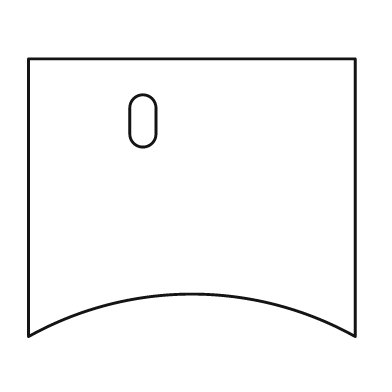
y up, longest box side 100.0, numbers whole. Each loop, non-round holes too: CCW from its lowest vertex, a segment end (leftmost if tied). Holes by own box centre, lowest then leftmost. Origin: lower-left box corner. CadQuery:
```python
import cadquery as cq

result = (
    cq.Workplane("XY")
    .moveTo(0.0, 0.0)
    .threePointArc((50.0, 13.0), (100.0, 0.0))
    .lineTo(100.0, 85.0)
    .lineTo(0.0, 85.0)
    .close()
    .moveTo(31.0, 62.0)
    .threePointArc((35.0, 58.0), (39.0, 62.0))
    .lineTo(39.0, 70.0)
    .threePointArc((35.0, 74.0), (31.0, 70.0))
    .close()
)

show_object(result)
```